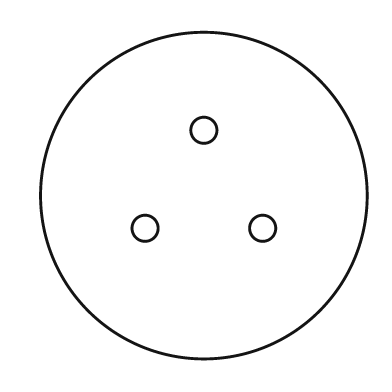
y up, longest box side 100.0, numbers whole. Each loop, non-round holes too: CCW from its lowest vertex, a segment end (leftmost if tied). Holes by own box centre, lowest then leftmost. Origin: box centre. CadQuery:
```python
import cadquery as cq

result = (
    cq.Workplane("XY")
    .moveTo(0.0, 0.0)
    .circle(50.0)
    .moveTo(-18.0, -10.0)
    .circle(4.0)
    .moveTo(18.0, -10.0)
    .circle(4.0)
    .moveTo(0.0, 20.0)
    .circle(4.0)
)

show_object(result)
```